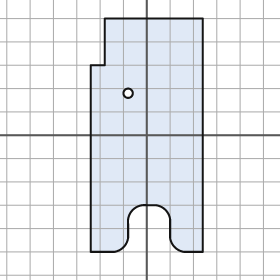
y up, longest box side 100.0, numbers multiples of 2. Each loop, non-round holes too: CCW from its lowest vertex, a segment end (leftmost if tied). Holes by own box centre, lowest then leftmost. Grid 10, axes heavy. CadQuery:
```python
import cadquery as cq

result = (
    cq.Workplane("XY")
    .moveTo(-24.0, -50.0)
    .lineTo(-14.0, -50.0)
    .threePointArc((-10.0, -48.0), (-8.0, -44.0))
    .lineTo(-8.0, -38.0)
    .threePointArc((-6.0, -32.0), (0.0, -30.0))
    .lineTo(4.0, -30.0)
    .threePointArc((8.0, -32.0), (10.0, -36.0))
    .lineTo(10.0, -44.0)
    .threePointArc((12.0, -48.0), (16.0, -50.0))
    .lineTo(24.0, -50.0)
    .lineTo(24.0, 50.0)
    .lineTo(-18.0, 50.0)
    .lineTo(-18.0, 30.0)
    .lineTo(-24.0, 30.0)
    .close()
    .moveTo(-8.0, 18.0)
    .circle(2.0)
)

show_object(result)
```